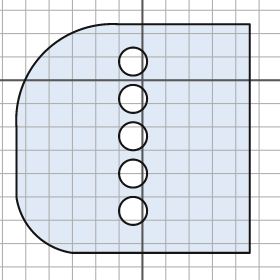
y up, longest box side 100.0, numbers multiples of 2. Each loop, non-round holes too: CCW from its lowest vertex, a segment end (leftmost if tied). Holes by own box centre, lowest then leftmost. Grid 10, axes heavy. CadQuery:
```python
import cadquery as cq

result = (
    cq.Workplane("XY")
    .moveTo(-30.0, -74.0)
    .lineTo(46.0, -74.0)
    .lineTo(46.0, 24.0)
    .lineTo(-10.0, 24.0)
    .threePointArc((-42.0, 12.0), (-54.0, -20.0))
    .lineTo(-54.0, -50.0)
    .threePointArc((-46.0, -66.0), (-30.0, -74.0))
    .close()
    .moveTo(-4.0, -56.0)
    .circle(6.0)
    .moveTo(-4.0, -40.0)
    .circle(6.0)
    .moveTo(-4.0, -24.0)
    .circle(6.0)
    .moveTo(-4.0, -8.0)
    .circle(6.0)
    .moveTo(-4.0, 8.0)
    .circle(6.0)
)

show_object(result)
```